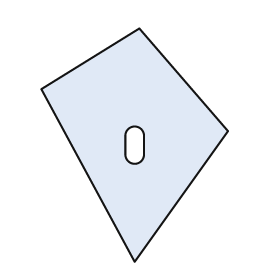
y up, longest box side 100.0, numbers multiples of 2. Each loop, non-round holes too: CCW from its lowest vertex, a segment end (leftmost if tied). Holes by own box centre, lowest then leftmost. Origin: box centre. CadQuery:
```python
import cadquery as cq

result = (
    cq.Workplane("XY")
    .moveTo(0.0, -50.0)
    .lineTo(40.0, 6.0)
    .lineTo(2.0, 50.0)
    .lineTo(-40.0, 24.0)
    .close()
    .moveTo(-4.0, -4.0)
    .threePointArc((0.0, -8.0), (4.0, -4.0))
    .lineTo(4.0, 4.0)
    .threePointArc((0.0, 8.0), (-4.0, 4.0))
    .close()
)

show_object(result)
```